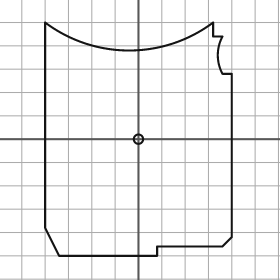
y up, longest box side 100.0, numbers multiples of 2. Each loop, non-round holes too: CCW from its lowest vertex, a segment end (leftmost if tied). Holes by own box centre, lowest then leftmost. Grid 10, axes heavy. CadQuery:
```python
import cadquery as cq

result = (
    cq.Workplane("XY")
    .moveTo(-34.0, -50.0)
    .lineTo(8.0, -50.0)
    .lineTo(8.0, -46.0)
    .lineTo(36.0, -46.0)
    .lineTo(40.0, -42.0)
    .lineTo(40.0, 28.0)
    .lineTo(36.0, 28.0)
    .threePointArc((34.0, 36.0), (36.0, 44.0))
    .lineTo(32.0, 44.0)
    .lineTo(32.0, 50.0)
    .threePointArc((-4.0, 38.0), (-40.0, 50.0))
    .lineTo(-40.0, -38.0)
    .close()
    .moveTo(0.0, 0.0)
    .circle(2.0)
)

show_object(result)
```